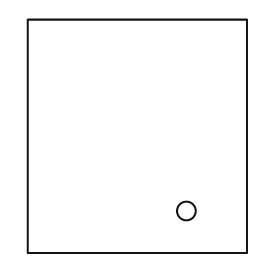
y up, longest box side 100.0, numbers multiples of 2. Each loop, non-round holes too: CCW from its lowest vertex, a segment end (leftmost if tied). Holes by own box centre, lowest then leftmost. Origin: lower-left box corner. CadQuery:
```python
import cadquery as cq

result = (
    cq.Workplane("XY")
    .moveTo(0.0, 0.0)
    .lineTo(94.0, 0.0)
    .lineTo(94.0, 100.0)
    .lineTo(0.0, 100.0)
    .close()
    .moveTo(68.0, 18.0)
    .circle(4.0)
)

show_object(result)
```